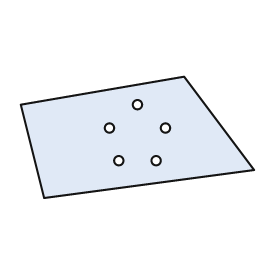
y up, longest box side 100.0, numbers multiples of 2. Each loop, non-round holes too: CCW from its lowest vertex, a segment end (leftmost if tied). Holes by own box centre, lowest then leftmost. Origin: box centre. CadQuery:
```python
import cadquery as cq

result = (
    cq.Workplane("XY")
    .moveTo(-40.0, -26.0)
    .lineTo(50.0, -14.0)
    .lineTo(20.0, 26.0)
    .lineTo(-50.0, 14.0)
    .close()
    .moveTo(-8.0, -10.0)
    .circle(2.0)
    .moveTo(8.0, -10.0)
    .circle(2.0)
    .moveTo(-12.0, 4.0)
    .circle(2.0)
    .moveTo(12.0, 4.0)
    .circle(2.0)
    .moveTo(0.0, 14.0)
    .circle(2.0)
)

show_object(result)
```